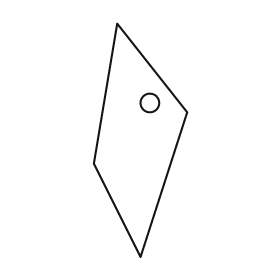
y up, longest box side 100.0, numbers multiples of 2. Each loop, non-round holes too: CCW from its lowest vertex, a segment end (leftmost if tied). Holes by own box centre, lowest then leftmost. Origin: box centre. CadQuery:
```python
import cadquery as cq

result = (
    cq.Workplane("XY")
    .moveTo(0.0, -50.0)
    .lineTo(20.0, 12.0)
    .lineTo(-10.0, 50.0)
    .lineTo(-20.0, -10.0)
    .close()
    .moveTo(4.0, 16.0)
    .circle(4.0)
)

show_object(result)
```